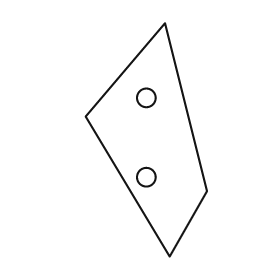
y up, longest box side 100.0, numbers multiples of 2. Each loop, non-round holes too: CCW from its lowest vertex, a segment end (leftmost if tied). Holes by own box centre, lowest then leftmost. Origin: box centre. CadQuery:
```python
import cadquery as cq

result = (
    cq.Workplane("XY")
    .moveTo(10.0, -50.0)
    .lineTo(26.0, -22.0)
    .lineTo(8.0, 50.0)
    .lineTo(-26.0, 10.0)
    .close()
    .moveTo(0.0, -16.0)
    .circle(4.0)
    .moveTo(0.0, 18.0)
    .circle(4.0)
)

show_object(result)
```